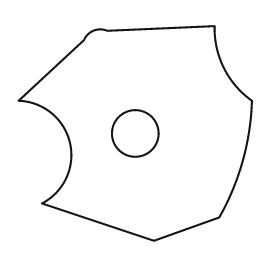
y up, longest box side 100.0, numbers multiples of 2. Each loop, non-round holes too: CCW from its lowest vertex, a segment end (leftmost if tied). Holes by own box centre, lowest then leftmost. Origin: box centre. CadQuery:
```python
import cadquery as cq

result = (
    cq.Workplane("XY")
    .moveTo(8.0, -46.0)
    .lineTo(36.0, -36.0)
    .threePointArc((46.0, -12.0), (50.0, 14.0))
    .threePointArc((38.0, 28.0), (34.0, 46.0))
    .lineTo(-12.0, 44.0)
    .threePointArc((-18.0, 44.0), (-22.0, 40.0))
    .lineTo(-50.0, 14.0)
    .threePointArc((-28.0, -4.0), (-40.0, -30.0))
    .close()
    .moveTo(0.0, 0.0)
    .circle(10.0)
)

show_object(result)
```